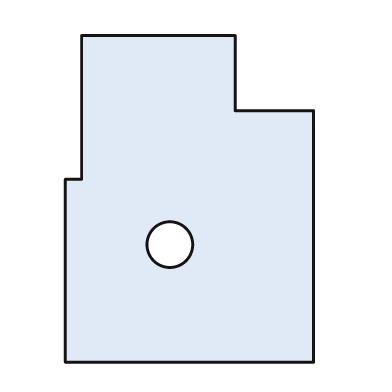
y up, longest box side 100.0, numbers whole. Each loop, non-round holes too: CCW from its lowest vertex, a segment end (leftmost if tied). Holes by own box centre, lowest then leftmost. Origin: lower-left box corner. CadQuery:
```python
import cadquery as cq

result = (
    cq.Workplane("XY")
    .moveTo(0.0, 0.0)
    .lineTo(76.0, 0.0)
    .lineTo(76.0, 77.0)
    .lineTo(52.0, 77.0)
    .lineTo(52.0, 100.0)
    .lineTo(5.0, 100.0)
    .lineTo(5.0, 56.0)
    .lineTo(0.0, 56.0)
    .close()
    .moveTo(32.0, 36.0)
    .circle(7.0)
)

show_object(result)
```